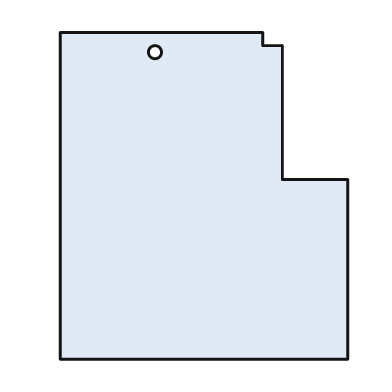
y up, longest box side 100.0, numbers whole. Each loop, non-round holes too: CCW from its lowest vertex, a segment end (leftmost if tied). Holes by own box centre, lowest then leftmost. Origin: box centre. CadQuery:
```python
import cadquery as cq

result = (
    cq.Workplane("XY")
    .moveTo(-44.0, -50.0)
    .lineTo(44.0, -50.0)
    .lineTo(44.0, 5.0)
    .lineTo(24.0, 5.0)
    .lineTo(24.0, 46.0)
    .lineTo(18.0, 46.0)
    .lineTo(18.0, 50.0)
    .lineTo(-44.0, 50.0)
    .close()
    .moveTo(-15.0, 44.0)
    .circle(2.0)
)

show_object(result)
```